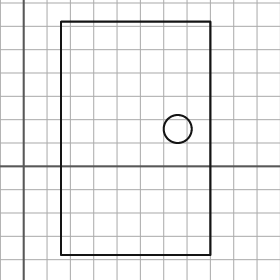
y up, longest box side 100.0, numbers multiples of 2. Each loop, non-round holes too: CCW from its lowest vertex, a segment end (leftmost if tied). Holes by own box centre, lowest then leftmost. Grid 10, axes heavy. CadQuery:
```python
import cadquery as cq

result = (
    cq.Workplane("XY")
    .moveTo(16.0, -38.0)
    .lineTo(80.0, -38.0)
    .lineTo(80.0, 62.0)
    .lineTo(16.0, 62.0)
    .close()
    .moveTo(66.0, 16.0)
    .circle(6.0)
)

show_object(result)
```